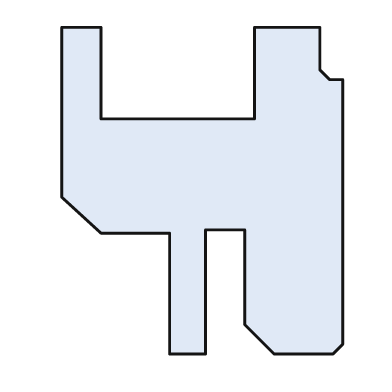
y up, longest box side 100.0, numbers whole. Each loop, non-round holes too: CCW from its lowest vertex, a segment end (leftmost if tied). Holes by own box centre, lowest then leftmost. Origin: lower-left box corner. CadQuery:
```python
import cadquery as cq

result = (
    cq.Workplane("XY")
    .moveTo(33.0, 0.0)
    .lineTo(44.0, 0.0)
    .lineTo(44.0, 38.0)
    .lineTo(56.0, 38.0)
    .lineTo(56.0, 9.0)
    .lineTo(65.0, 0.0)
    .lineTo(83.0, 0.0)
    .lineTo(86.0, 3.0)
    .lineTo(86.0, 84.0)
    .lineTo(82.0, 84.0)
    .lineTo(79.0, 87.0)
    .lineTo(79.0, 100.0)
    .lineTo(59.0, 100.0)
    .lineTo(59.0, 72.0)
    .lineTo(12.0, 72.0)
    .lineTo(12.0, 100.0)
    .lineTo(0.0, 100.0)
    .lineTo(0.0, 48.0)
    .lineTo(12.0, 37.0)
    .lineTo(33.0, 37.0)
    .close()
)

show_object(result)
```